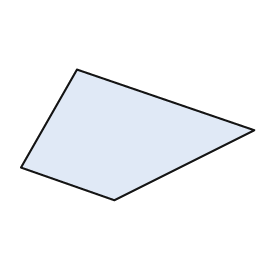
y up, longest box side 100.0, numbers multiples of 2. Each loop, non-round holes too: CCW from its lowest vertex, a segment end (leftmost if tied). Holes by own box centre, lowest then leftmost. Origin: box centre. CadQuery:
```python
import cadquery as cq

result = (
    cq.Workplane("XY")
    .moveTo(-10.0, -28.0)
    .lineTo(50.0, 2.0)
    .lineTo(-26.0, 28.0)
    .lineTo(-50.0, -14.0)
    .close()
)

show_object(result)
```